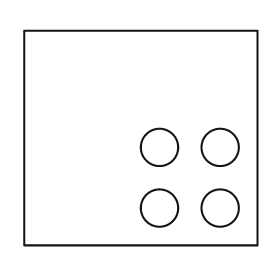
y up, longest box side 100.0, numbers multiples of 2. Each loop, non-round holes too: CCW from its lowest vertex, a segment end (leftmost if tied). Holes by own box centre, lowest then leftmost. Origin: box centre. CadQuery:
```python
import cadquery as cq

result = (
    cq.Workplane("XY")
    .moveTo(-50.0, -46.0)
    .lineTo(50.0, -46.0)
    .lineTo(50.0, 46.0)
    .lineTo(-50.0, 46.0)
    .close()
    .moveTo(8.0, -30.0)
    .circle(8.0)
    .moveTo(34.0, -30.0)
    .circle(8.0)
    .moveTo(8.0, -4.0)
    .circle(8.0)
    .moveTo(34.0, -4.0)
    .circle(8.0)
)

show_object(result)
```